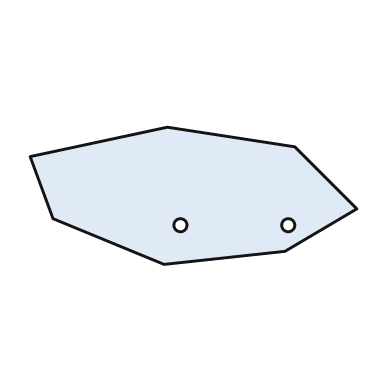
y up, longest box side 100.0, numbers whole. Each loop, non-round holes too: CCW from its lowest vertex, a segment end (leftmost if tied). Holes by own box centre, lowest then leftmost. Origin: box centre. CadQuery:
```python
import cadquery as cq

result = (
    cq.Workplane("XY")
    .moveTo(-9.0, -21.0)
    .lineTo(28.0, -17.0)
    .lineTo(50.0, -4.0)
    .lineTo(31.0, 15.0)
    .lineTo(-8.0, 21.0)
    .lineTo(-50.0, 12.0)
    .lineTo(-43.0, -7.0)
    .close()
    .moveTo(-4.0, -9.0)
    .circle(2.0)
    .moveTo(29.0, -9.0)
    .circle(2.0)
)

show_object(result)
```